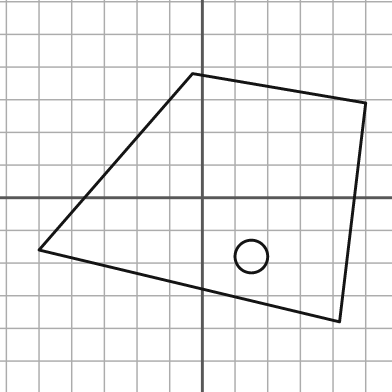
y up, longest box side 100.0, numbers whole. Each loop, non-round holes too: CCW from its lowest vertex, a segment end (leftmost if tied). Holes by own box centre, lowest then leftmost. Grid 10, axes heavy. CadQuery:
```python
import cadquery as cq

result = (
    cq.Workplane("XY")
    .moveTo(42.0, -38.0)
    .lineTo(50.0, 29.0)
    .lineTo(-3.0, 38.0)
    .lineTo(-50.0, -16.0)
    .close()
    .moveTo(15.0, -18.0)
    .circle(5.0)
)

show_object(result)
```